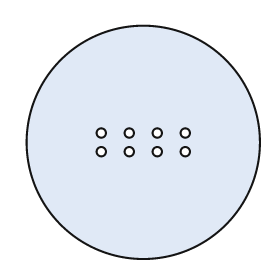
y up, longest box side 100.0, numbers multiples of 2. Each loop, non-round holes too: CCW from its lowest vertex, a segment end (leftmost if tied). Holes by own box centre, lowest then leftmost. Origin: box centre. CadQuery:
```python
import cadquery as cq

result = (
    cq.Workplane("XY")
    .moveTo(0.0, 0.0)
    .circle(50.0)
    .moveTo(-18.0, -4.0)
    .circle(2.0)
    .moveTo(-6.0, -4.0)
    .circle(2.0)
    .moveTo(6.0, -4.0)
    .circle(2.0)
    .moveTo(18.0, -4.0)
    .circle(2.0)
    .moveTo(-18.0, 4.0)
    .circle(2.0)
    .moveTo(-6.0, 4.0)
    .circle(2.0)
    .moveTo(6.0, 4.0)
    .circle(2.0)
    .moveTo(18.0, 4.0)
    .circle(2.0)
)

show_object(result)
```